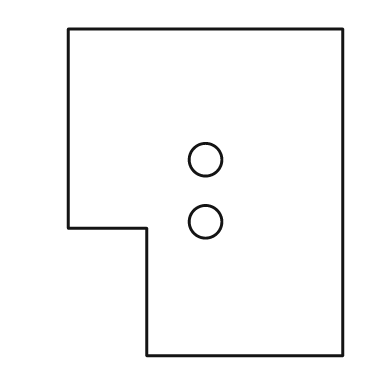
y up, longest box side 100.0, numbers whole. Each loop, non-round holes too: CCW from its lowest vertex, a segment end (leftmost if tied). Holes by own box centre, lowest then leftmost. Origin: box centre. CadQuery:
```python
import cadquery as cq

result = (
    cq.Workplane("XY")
    .moveTo(-18.0, -50.0)
    .lineTo(42.0, -50.0)
    .lineTo(42.0, 50.0)
    .lineTo(-42.0, 50.0)
    .lineTo(-42.0, -11.0)
    .lineTo(-18.0, -11.0)
    .close()
    .moveTo(0.0, -9.0)
    .circle(5.0)
    .moveTo(0.0, 10.0)
    .circle(5.0)
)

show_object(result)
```